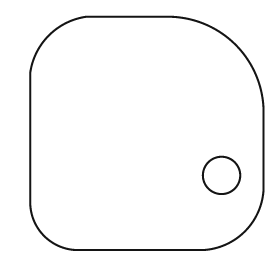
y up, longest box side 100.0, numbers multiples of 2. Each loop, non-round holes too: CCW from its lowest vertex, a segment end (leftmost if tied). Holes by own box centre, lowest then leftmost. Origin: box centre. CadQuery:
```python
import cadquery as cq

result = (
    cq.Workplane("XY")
    .moveTo(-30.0, -50.0)
    .lineTo(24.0, -50.0)
    .threePointArc((42.0, -42.0), (50.0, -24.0))
    .lineTo(50.0, 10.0)
    .threePointArc((38.0, 38.0), (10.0, 50.0))
    .lineTo(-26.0, 50.0)
    .threePointArc((-42.0, 42.0), (-50.0, 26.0))
    .lineTo(-50.0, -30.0)
    .threePointArc((-44.0, -44.0), (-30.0, -50.0))
    .close()
    .moveTo(32.0, -18.0)
    .circle(8.0)
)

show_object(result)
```